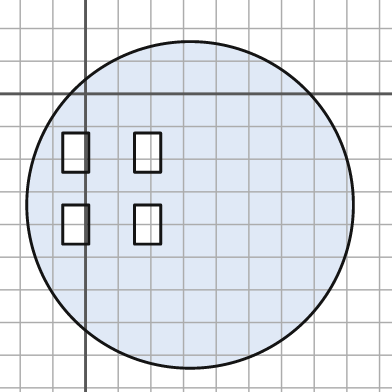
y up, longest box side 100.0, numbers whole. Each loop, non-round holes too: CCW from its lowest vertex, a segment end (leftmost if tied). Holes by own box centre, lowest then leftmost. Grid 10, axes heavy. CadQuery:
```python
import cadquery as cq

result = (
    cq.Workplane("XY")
    .moveTo(32.0, -34.0)
    .circle(50.0)
    .moveTo(-7.0, -46.0)
    .lineTo(1.0, -46.0)
    .lineTo(1.0, -34.0)
    .lineTo(-7.0, -34.0)
    .close()
    .moveTo(15.0, -46.0)
    .lineTo(23.0, -46.0)
    .lineTo(23.0, -34.0)
    .lineTo(15.0, -34.0)
    .close()
    .moveTo(-7.0, -24.0)
    .lineTo(1.0, -24.0)
    .lineTo(1.0, -12.0)
    .lineTo(-7.0, -12.0)
    .close()
    .moveTo(15.0, -24.0)
    .lineTo(23.0, -24.0)
    .lineTo(23.0, -12.0)
    .lineTo(15.0, -12.0)
    .close()
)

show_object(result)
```